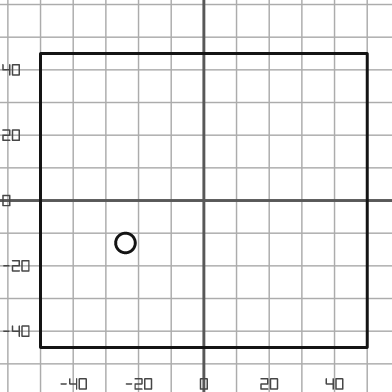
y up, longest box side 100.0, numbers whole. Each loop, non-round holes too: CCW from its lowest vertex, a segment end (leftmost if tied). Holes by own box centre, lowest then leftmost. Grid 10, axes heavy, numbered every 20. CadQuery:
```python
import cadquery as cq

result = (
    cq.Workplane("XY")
    .moveTo(-50.0, -45.0)
    .lineTo(50.0, -45.0)
    .lineTo(50.0, 45.0)
    .lineTo(-50.0, 45.0)
    .close()
    .moveTo(-24.0, -13.0)
    .circle(3.0)
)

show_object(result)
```